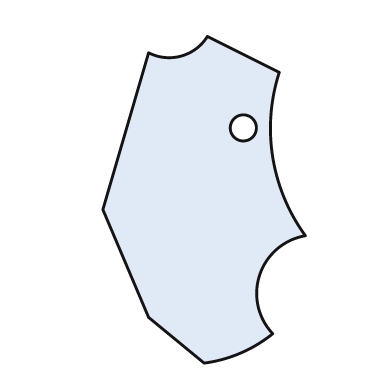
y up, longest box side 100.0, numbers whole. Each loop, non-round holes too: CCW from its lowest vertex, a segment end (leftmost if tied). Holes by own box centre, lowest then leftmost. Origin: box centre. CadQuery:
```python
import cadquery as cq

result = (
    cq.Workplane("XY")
    .moveTo(0.0, -50.0)
    .threePointArc((11.0, -47.0), (21.0, -41.0))
    .threePointArc((17.0, -23.0), (31.0, -11.0))
    .threePointArc((21.0, 13.0), (23.0, 39.0))
    .lineTo(1.0, 50.0)
    .threePointArc((-7.0, 44.0), (-17.0, 45.0))
    .lineTo(-31.0, -3.0)
    .lineTo(-17.0, -36.0)
    .close()
    .moveTo(12.0, 22.0)
    .circle(4.0)
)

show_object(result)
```